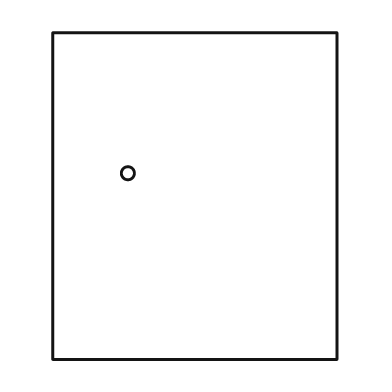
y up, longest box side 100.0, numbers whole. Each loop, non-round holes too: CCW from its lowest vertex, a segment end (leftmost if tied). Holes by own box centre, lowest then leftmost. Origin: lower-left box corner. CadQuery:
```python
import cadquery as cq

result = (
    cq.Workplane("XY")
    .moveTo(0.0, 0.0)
    .lineTo(87.0, 0.0)
    .lineTo(87.0, 100.0)
    .lineTo(0.0, 100.0)
    .close()
    .moveTo(23.0, 57.0)
    .circle(2.0)
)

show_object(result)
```